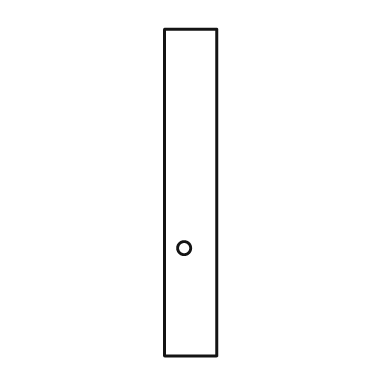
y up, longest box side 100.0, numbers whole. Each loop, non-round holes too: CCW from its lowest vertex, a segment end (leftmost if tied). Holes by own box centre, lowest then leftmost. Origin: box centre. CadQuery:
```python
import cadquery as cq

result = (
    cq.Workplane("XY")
    .moveTo(-8.0, -50.0)
    .lineTo(8.0, -50.0)
    .lineTo(8.0, 50.0)
    .lineTo(-8.0, 50.0)
    .close()
    .moveTo(-2.0, -17.0)
    .circle(2.0)
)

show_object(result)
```